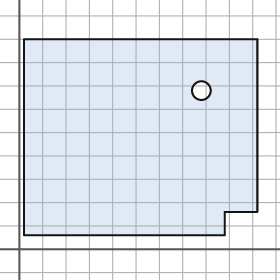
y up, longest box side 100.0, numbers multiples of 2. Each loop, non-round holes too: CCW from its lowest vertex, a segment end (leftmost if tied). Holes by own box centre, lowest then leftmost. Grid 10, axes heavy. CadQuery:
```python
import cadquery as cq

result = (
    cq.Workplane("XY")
    .moveTo(2.0, 6.0)
    .lineTo(88.0, 6.0)
    .lineTo(88.0, 16.0)
    .lineTo(102.0, 16.0)
    .lineTo(102.0, 90.0)
    .lineTo(2.0, 90.0)
    .close()
    .moveTo(78.0, 68.0)
    .circle(4.0)
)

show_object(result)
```